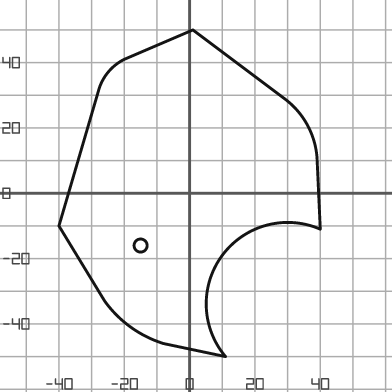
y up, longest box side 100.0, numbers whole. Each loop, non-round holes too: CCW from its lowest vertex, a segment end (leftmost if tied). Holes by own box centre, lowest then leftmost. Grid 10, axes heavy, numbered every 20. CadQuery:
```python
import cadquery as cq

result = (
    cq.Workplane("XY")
    .moveTo(11.0, -50.0)
    .threePointArc((10.0, -19.0), (40.0, -11.0))
    .lineTo(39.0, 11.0)
    .threePointArc((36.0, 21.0), (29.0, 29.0))
    .lineTo(1.0, 50.0)
    .lineTo(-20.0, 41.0)
    .threePointArc((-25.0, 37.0), (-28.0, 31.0))
    .lineTo(-40.0, -10.0)
    .lineTo(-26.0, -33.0)
    .threePointArc((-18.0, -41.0), (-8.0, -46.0))
    .close()
    .moveTo(-15.0, -16.0)
    .circle(2.0)
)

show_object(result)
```